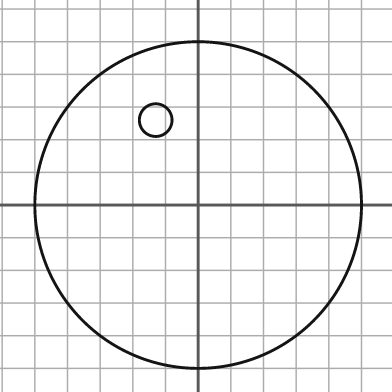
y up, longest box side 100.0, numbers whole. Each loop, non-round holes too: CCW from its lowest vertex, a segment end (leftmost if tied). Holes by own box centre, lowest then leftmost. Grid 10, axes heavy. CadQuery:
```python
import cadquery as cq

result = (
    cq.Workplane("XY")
    .moveTo(0.0, 0.0)
    .circle(50.0)
    .moveTo(-13.0, 26.0)
    .circle(5.0)
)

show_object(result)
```